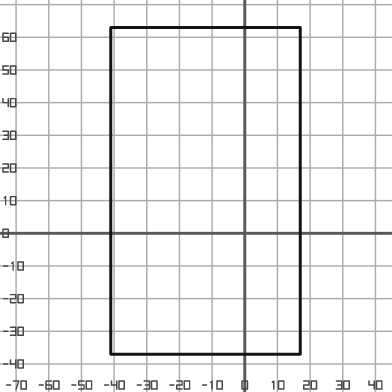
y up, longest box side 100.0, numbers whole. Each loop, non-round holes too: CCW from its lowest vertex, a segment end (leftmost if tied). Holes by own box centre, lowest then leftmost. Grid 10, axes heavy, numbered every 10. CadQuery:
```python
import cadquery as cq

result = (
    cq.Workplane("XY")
    .moveTo(-41.0, -37.0)
    .lineTo(17.0, -37.0)
    .lineTo(17.0, 63.0)
    .lineTo(-41.0, 63.0)
    .close()
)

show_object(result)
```